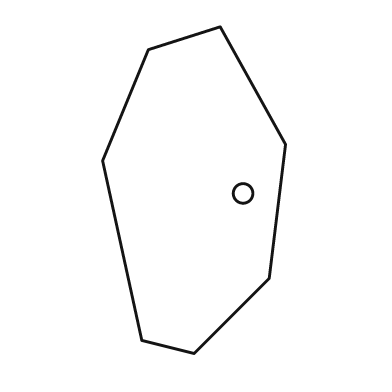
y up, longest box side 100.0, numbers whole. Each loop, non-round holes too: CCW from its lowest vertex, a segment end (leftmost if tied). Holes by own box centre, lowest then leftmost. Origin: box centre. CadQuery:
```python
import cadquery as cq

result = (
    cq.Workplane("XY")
    .moveTo(0.0, -50.0)
    .lineTo(23.0, -27.0)
    .lineTo(28.0, 14.0)
    .lineTo(8.0, 50.0)
    .lineTo(-14.0, 43.0)
    .lineTo(-28.0, 9.0)
    .lineTo(-16.0, -46.0)
    .close()
    .moveTo(15.0, -1.0)
    .circle(3.0)
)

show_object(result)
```